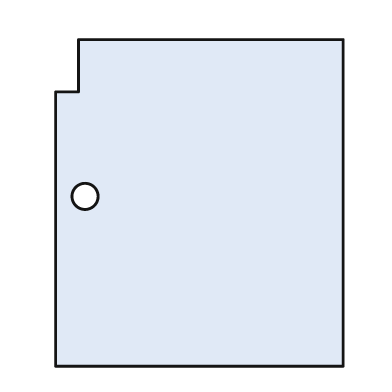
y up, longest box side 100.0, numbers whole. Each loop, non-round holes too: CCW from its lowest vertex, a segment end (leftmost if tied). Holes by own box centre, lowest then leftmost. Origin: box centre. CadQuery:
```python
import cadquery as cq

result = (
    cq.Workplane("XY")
    .moveTo(-44.0, -50.0)
    .lineTo(44.0, -50.0)
    .lineTo(44.0, 50.0)
    .lineTo(-37.0, 50.0)
    .lineTo(-37.0, 34.0)
    .lineTo(-44.0, 34.0)
    .close()
    .moveTo(-35.0, 2.0)
    .circle(4.0)
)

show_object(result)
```